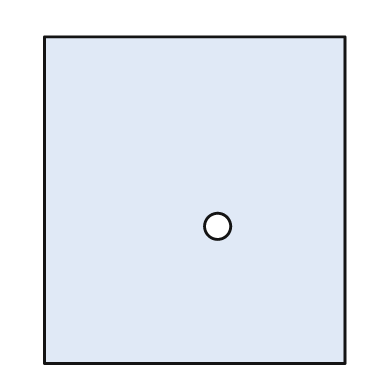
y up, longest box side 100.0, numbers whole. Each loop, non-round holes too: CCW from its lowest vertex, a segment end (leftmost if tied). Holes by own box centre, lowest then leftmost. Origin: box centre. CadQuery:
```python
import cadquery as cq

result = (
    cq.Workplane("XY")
    .moveTo(-46.0, -50.0)
    .lineTo(46.0, -50.0)
    .lineTo(46.0, 50.0)
    .lineTo(-46.0, 50.0)
    .close()
    .moveTo(7.0, -8.0)
    .circle(4.0)
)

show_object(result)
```